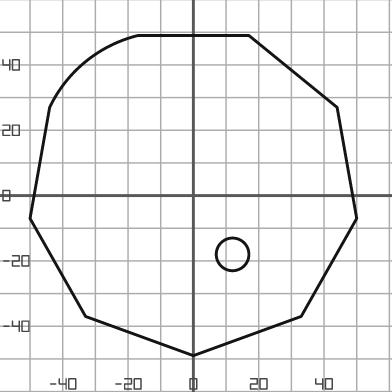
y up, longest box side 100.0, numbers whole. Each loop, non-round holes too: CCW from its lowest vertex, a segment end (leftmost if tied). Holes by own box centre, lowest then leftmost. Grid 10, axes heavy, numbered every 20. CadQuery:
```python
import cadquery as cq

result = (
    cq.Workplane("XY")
    .moveTo(0.0, -49.0)
    .lineTo(33.0, -37.0)
    .lineTo(50.0, -7.0)
    .lineTo(44.0, 27.0)
    .lineTo(17.0, 49.0)
    .lineTo(-17.0, 49.0)
    .threePointArc((-33.0, 41.0), (-44.0, 27.0))
    .lineTo(-50.0, -7.0)
    .lineTo(-33.0, -37.0)
    .close()
    .moveTo(12.0, -18.0)
    .circle(5.0)
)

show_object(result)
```